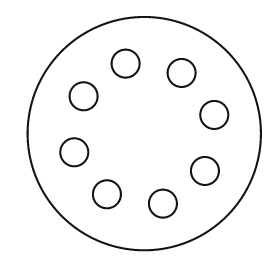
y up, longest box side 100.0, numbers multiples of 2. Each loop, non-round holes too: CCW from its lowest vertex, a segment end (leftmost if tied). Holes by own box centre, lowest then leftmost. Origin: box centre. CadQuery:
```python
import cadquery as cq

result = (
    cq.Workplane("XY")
    .moveTo(0.0, 0.0)
    .circle(50.0)
    .moveTo(8.0, -30.0)
    .circle(6.0)
    .moveTo(-16.0, -26.0)
    .circle(6.0)
    .moveTo(26.0, -16.0)
    .circle(6.0)
    .moveTo(-30.0, -8.0)
    .circle(6.0)
    .moveTo(30.0, 8.0)
    .circle(6.0)
    .moveTo(-26.0, 16.0)
    .circle(6.0)
    .moveTo(16.0, 26.0)
    .circle(6.0)
    .moveTo(-8.0, 30.0)
    .circle(6.0)
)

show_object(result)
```